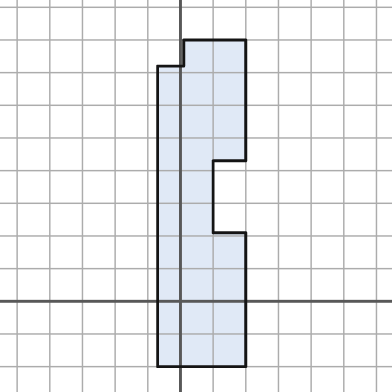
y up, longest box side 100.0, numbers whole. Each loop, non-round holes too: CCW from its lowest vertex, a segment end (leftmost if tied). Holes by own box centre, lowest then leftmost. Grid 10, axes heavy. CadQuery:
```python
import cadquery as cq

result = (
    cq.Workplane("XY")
    .moveTo(-7.0, -20.0)
    .lineTo(20.0, -20.0)
    .lineTo(20.0, 21.0)
    .lineTo(10.0, 21.0)
    .lineTo(10.0, 43.0)
    .lineTo(20.0, 43.0)
    .lineTo(20.0, 80.0)
    .lineTo(1.0, 80.0)
    .lineTo(1.0, 72.0)
    .lineTo(-7.0, 72.0)
    .close()
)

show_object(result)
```